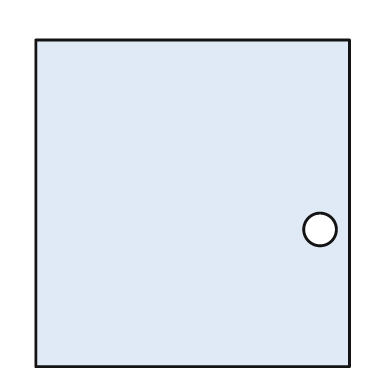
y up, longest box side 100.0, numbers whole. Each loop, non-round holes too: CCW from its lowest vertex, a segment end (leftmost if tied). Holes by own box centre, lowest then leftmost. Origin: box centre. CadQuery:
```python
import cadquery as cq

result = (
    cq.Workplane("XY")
    .moveTo(-48.0, -50.0)
    .lineTo(48.0, -50.0)
    .lineTo(48.0, 50.0)
    .lineTo(-48.0, 50.0)
    .close()
    .moveTo(39.0, -8.0)
    .circle(5.0)
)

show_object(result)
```